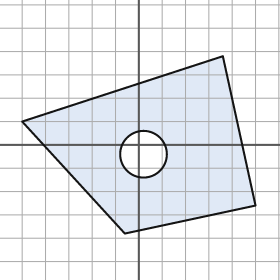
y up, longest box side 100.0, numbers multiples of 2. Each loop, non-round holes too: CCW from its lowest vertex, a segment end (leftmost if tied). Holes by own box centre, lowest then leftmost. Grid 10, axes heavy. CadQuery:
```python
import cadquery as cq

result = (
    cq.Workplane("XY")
    .moveTo(-6.0, -38.0)
    .lineTo(50.0, -26.0)
    .lineTo(36.0, 38.0)
    .lineTo(-50.0, 10.0)
    .close()
    .moveTo(2.0, -4.0)
    .circle(10.0)
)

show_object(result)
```